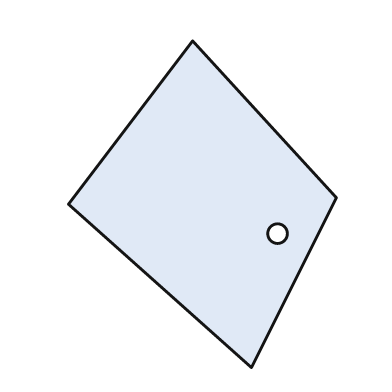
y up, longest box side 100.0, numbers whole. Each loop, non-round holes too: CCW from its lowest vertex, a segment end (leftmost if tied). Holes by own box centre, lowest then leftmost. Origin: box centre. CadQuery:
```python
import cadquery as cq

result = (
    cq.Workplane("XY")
    .moveTo(15.0, -50.0)
    .lineTo(41.0, 2.0)
    .lineTo(-3.0, 50.0)
    .lineTo(-41.0, 0.0)
    .close()
    .moveTo(23.0, -9.0)
    .circle(3.0)
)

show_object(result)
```